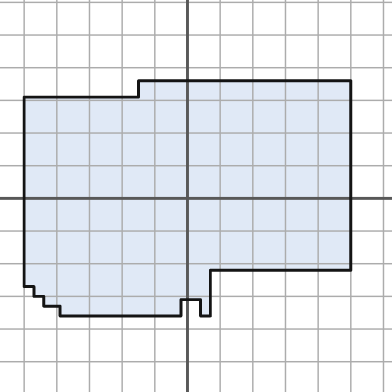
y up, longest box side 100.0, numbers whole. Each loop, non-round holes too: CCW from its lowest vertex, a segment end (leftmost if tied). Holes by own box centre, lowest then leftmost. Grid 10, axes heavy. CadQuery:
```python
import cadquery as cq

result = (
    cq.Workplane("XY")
    .moveTo(-39.0, -36.0)
    .lineTo(-2.0, -36.0)
    .lineTo(-2.0, -31.0)
    .lineTo(4.0, -31.0)
    .lineTo(4.0, -36.0)
    .lineTo(7.0, -36.0)
    .lineTo(7.0, -22.0)
    .lineTo(50.0, -22.0)
    .lineTo(50.0, 36.0)
    .lineTo(-15.0, 36.0)
    .lineTo(-15.0, 31.0)
    .lineTo(-50.0, 31.0)
    .lineTo(-50.0, -27.0)
    .lineTo(-47.0, -27.0)
    .lineTo(-47.0, -30.0)
    .lineTo(-44.0, -30.0)
    .lineTo(-44.0, -33.0)
    .lineTo(-39.0, -33.0)
    .close()
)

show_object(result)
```